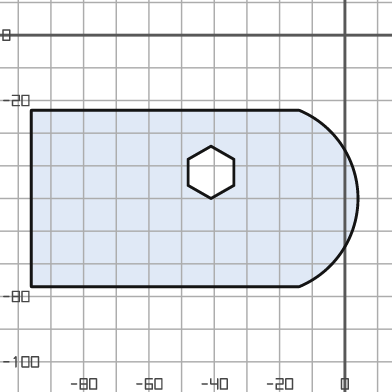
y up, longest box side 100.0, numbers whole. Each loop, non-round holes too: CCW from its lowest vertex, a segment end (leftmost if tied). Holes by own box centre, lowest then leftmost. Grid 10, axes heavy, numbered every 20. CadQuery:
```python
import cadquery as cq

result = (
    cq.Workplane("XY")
    .moveTo(-96.0, -77.0)
    .lineTo(-14.0, -77.0)
    .threePointArc((4.0, -50.0), (-14.0, -23.0))
    .lineTo(-96.0, -23.0)
    .close()
    .moveTo(-41.0, -50.0)
    .lineTo(-34.0, -46.0)
    .lineTo(-34.0, -38.0)
    .lineTo(-41.0, -34.0)
    .lineTo(-48.0, -38.0)
    .lineTo(-48.0, -46.0)
    .close()
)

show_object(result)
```